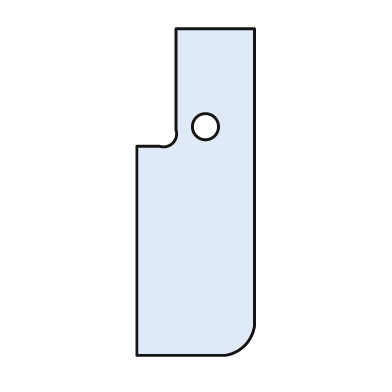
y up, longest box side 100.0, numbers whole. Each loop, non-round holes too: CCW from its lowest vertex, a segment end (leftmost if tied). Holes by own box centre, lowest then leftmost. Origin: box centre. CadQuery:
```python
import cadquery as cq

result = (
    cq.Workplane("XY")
    .moveTo(-18.0, -50.0)
    .lineTo(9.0, -50.0)
    .threePointArc((15.0, -47.0), (18.0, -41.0))
    .lineTo(18.0, 50.0)
    .lineTo(-6.0, 50.0)
    .lineTo(-6.0, 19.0)
    .threePointArc((-7.0, 15.0), (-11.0, 14.0))
    .lineTo(-18.0, 14.0)
    .close()
    .moveTo(3.0, 20.0)
    .circle(4.0)
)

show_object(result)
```